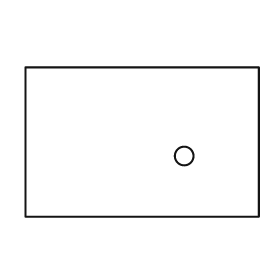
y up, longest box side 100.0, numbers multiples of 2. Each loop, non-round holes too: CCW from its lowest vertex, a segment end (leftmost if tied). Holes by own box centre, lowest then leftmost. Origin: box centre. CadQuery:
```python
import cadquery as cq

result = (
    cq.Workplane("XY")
    .moveTo(-50.0, -32.0)
    .lineTo(50.0, -32.0)
    .lineTo(50.0, 32.0)
    .lineTo(-50.0, 32.0)
    .close()
    .moveTo(18.0, -6.0)
    .circle(4.0)
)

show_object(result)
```